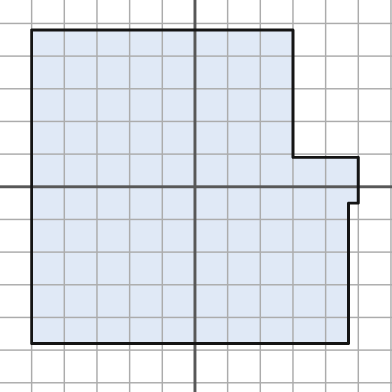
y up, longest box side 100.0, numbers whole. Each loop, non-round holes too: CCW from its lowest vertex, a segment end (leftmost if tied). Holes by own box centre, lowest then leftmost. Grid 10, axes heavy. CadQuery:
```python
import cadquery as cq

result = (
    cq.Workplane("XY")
    .moveTo(-50.0, -48.0)
    .lineTo(47.0, -48.0)
    .lineTo(47.0, -5.0)
    .lineTo(50.0, -5.0)
    .lineTo(50.0, 9.0)
    .lineTo(30.0, 9.0)
    .lineTo(30.0, 48.0)
    .lineTo(-50.0, 48.0)
    .close()
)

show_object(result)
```